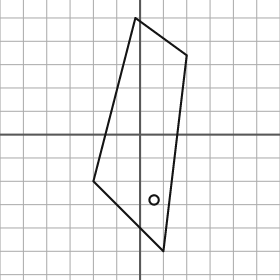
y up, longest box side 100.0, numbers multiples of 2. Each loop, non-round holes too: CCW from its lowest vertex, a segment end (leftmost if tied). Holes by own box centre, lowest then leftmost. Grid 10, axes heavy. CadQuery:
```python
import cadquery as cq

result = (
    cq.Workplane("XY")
    .moveTo(10.0, -50.0)
    .lineTo(20.0, 34.0)
    .lineTo(-2.0, 50.0)
    .lineTo(-20.0, -20.0)
    .close()
    .moveTo(6.0, -28.0)
    .circle(2.0)
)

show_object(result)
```